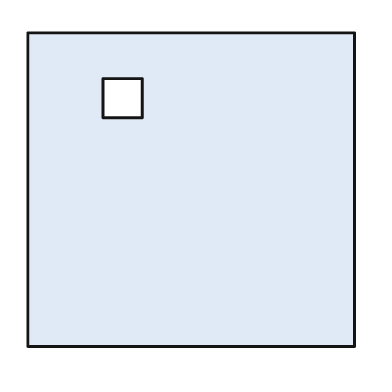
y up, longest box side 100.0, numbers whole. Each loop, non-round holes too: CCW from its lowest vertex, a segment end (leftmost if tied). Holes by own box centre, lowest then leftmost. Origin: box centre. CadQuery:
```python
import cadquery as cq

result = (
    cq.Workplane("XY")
    .moveTo(-50.0, -48.0)
    .lineTo(50.0, -48.0)
    .lineTo(50.0, 48.0)
    .lineTo(-50.0, 48.0)
    .close()
    .moveTo(-27.0, 22.0)
    .lineTo(-15.0, 22.0)
    .lineTo(-15.0, 34.0)
    .lineTo(-27.0, 34.0)
    .close()
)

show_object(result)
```